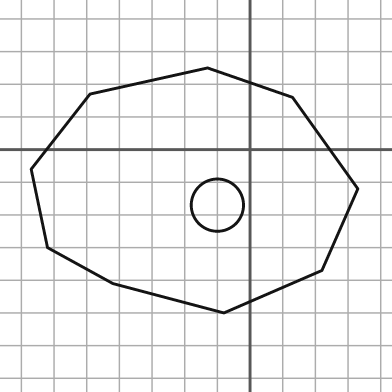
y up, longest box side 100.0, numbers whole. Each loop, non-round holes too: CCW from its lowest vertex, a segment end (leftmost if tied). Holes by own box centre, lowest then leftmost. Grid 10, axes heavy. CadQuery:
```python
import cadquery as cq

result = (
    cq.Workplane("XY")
    .moveTo(-8.0, -50.0)
    .lineTo(22.0, -37.0)
    .lineTo(33.0, -12.0)
    .lineTo(13.0, 16.0)
    .lineTo(-13.0, 25.0)
    .lineTo(-49.0, 17.0)
    .lineTo(-67.0, -6.0)
    .lineTo(-62.0, -30.0)
    .lineTo(-42.0, -41.0)
    .close()
    .moveTo(-10.0, -17.0)
    .circle(8.0)
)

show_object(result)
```